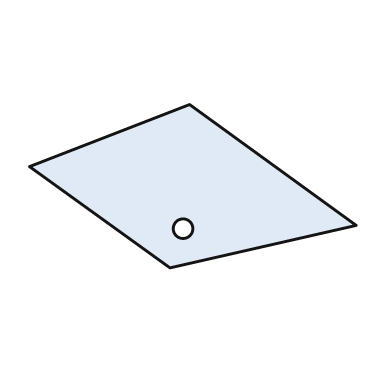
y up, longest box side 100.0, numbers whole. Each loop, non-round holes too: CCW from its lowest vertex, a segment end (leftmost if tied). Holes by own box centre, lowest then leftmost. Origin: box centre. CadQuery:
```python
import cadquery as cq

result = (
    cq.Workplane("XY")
    .moveTo(-7.0, -25.0)
    .lineTo(50.0, -12.0)
    .lineTo(-1.0, 25.0)
    .lineTo(-50.0, 6.0)
    .close()
    .moveTo(-3.0, -13.0)
    .circle(3.0)
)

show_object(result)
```